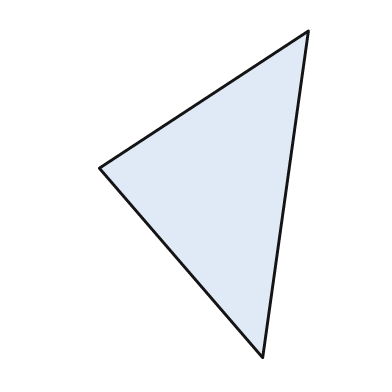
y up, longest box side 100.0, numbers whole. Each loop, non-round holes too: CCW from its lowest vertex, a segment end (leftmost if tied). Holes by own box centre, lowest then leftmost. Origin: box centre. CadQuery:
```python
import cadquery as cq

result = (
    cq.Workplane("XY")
    .moveTo(18.0, -50.0)
    .lineTo(32.0, 50.0)
    .lineTo(-32.0, 8.0)
    .close()
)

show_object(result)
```